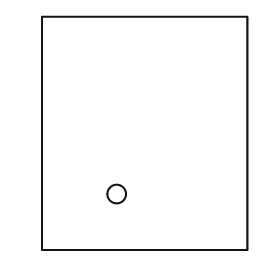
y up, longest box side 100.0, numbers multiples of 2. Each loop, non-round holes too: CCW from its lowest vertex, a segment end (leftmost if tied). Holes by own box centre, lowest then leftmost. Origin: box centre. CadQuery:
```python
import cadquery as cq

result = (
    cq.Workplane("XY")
    .moveTo(-44.0, -50.0)
    .lineTo(44.0, -50.0)
    .lineTo(44.0, 50.0)
    .lineTo(-44.0, 50.0)
    .close()
    .moveTo(-12.0, -26.0)
    .circle(4.0)
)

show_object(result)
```